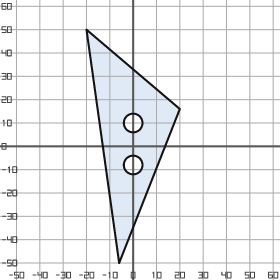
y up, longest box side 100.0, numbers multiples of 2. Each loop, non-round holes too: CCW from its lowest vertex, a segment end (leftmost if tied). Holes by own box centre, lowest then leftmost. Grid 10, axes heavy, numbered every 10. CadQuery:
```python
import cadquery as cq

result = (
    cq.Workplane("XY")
    .moveTo(-6.0, -50.0)
    .lineTo(20.0, 16.0)
    .lineTo(-20.0, 50.0)
    .close()
    .moveTo(0.0, -8.0)
    .circle(4.0)
    .moveTo(0.0, 10.0)
    .circle(4.0)
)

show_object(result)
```